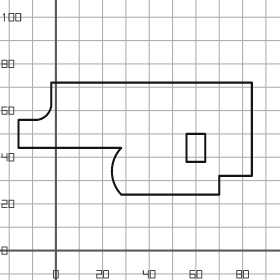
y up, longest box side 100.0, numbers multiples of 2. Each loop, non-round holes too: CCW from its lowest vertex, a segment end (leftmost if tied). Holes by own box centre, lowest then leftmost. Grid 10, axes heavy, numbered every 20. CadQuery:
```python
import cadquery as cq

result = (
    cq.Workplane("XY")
    .moveTo(28.0, 24.0)
    .lineTo(70.0, 24.0)
    .lineTo(70.0, 32.0)
    .lineTo(84.0, 32.0)
    .lineTo(84.0, 72.0)
    .lineTo(-2.0, 72.0)
    .lineTo(-2.0, 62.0)
    .threePointArc((-4.0, 58.0), (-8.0, 56.0))
    .lineTo(-16.0, 56.0)
    .lineTo(-16.0, 44.0)
    .lineTo(28.0, 44.0)
    .threePointArc((24.0, 34.0), (28.0, 24.0))
    .close()
    .moveTo(56.0, 38.0)
    .lineTo(64.0, 38.0)
    .lineTo(64.0, 50.0)
    .lineTo(56.0, 50.0)
    .close()
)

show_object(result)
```